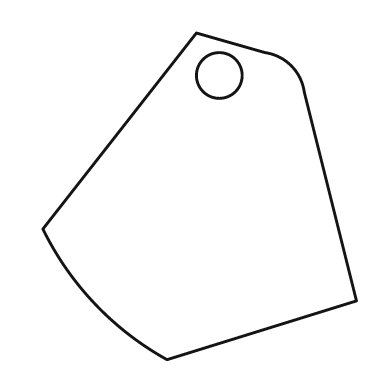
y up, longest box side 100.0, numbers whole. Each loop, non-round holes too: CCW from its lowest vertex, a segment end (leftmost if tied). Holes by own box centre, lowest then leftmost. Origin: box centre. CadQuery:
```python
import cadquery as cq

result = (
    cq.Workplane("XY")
    .moveTo(-10.0, -50.0)
    .lineTo(48.0, -32.0)
    .lineTo(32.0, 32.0)
    .threePointArc((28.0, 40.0), (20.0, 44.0))
    .lineTo(-1.0, 50.0)
    .lineTo(-48.0, -10.0)
    .threePointArc((-32.0, -33.0), (-10.0, -50.0))
    .close()
    .moveTo(6.0, 37.0)
    .circle(7.0)
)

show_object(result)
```